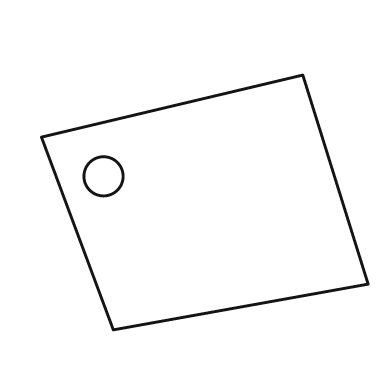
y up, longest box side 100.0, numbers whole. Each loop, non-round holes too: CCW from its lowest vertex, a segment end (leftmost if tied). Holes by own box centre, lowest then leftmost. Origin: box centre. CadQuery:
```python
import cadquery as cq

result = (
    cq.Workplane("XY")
    .moveTo(-28.0, -39.0)
    .lineTo(50.0, -25.0)
    .lineTo(30.0, 39.0)
    .lineTo(-50.0, 20.0)
    .close()
    .moveTo(-31.0, 8.0)
    .circle(6.0)
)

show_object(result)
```